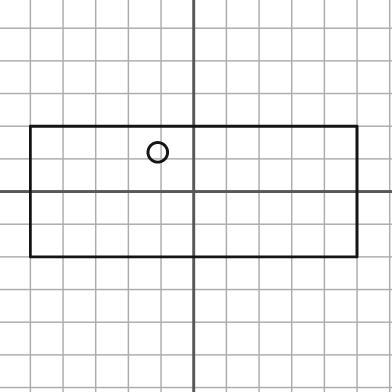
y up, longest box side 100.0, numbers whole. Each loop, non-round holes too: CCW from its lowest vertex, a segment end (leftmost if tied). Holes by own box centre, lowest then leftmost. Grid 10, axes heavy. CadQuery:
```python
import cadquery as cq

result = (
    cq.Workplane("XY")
    .moveTo(-50.0, -20.0)
    .lineTo(50.0, -20.0)
    .lineTo(50.0, 20.0)
    .lineTo(-50.0, 20.0)
    .close()
    .moveTo(-11.0, 12.0)
    .circle(3.0)
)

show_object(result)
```